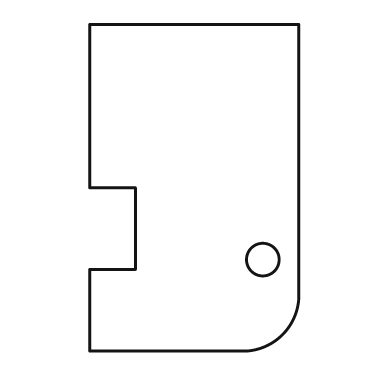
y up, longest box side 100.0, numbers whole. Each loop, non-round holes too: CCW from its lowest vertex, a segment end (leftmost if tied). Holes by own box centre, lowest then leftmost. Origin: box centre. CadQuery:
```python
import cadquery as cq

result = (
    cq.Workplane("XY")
    .moveTo(-32.0, -50.0)
    .lineTo(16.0, -50.0)
    .threePointArc((27.0, -45.0), (32.0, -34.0))
    .lineTo(32.0, 50.0)
    .lineTo(-32.0, 50.0)
    .lineTo(-32.0, 0.0)
    .lineTo(-18.0, 0.0)
    .lineTo(-18.0, -25.0)
    .lineTo(-32.0, -25.0)
    .close()
    .moveTo(21.0, -22.0)
    .circle(5.0)
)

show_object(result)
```